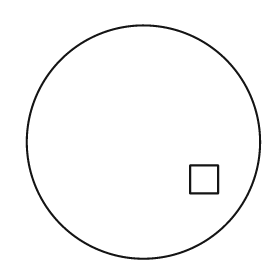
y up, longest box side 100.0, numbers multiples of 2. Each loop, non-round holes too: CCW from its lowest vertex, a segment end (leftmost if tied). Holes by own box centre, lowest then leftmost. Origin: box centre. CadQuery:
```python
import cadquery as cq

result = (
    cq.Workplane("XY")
    .moveTo(0.0, 0.0)
    .circle(50.0)
    .moveTo(20.0, -22.0)
    .lineTo(32.0, -22.0)
    .lineTo(32.0, -10.0)
    .lineTo(20.0, -10.0)
    .close()
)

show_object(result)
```